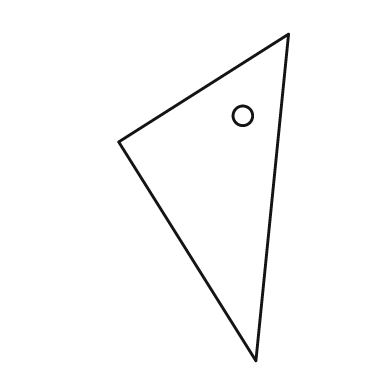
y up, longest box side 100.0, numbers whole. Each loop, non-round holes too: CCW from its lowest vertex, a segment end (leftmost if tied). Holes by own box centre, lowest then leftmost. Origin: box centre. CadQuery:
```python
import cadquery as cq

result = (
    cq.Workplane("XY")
    .moveTo(16.0, -50.0)
    .lineTo(26.0, 50.0)
    .lineTo(-26.0, 17.0)
    .close()
    .moveTo(12.0, 25.0)
    .circle(3.0)
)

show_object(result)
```